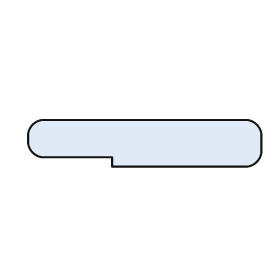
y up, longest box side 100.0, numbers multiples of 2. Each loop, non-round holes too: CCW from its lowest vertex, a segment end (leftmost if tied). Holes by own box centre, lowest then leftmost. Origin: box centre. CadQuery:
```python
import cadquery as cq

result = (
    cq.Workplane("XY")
    .moveTo(-14.0, -10.0)
    .lineTo(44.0, -10.0)
    .threePointArc((48.0, -8.0), (50.0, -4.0))
    .lineTo(50.0, 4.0)
    .threePointArc((48.0, 8.0), (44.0, 10.0))
    .lineTo(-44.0, 10.0)
    .threePointArc((-48.0, 8.0), (-50.0, 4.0))
    .lineTo(-50.0, 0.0)
    .threePointArc((-48.0, -4.0), (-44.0, -6.0))
    .lineTo(-14.0, -6.0)
    .close()
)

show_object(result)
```